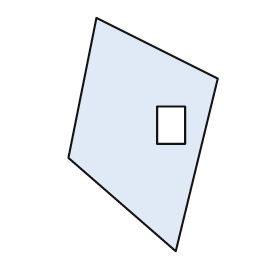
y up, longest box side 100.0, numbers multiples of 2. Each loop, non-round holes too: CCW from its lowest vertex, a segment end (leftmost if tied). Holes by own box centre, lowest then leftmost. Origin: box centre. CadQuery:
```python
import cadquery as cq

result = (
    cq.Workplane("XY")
    .moveTo(14.0, -50.0)
    .lineTo(32.0, 24.0)
    .lineTo(-20.0, 50.0)
    .lineTo(-32.0, -10.0)
    .close()
    .moveTo(6.0, -4.0)
    .lineTo(18.0, -4.0)
    .lineTo(18.0, 12.0)
    .lineTo(6.0, 12.0)
    .close()
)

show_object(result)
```